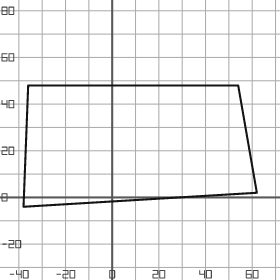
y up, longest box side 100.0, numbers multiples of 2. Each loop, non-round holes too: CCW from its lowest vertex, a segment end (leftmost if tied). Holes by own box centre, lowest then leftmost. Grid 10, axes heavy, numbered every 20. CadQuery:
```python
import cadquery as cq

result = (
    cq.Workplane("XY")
    .moveTo(-38.0, -4.0)
    .lineTo(62.0, 2.0)
    .lineTo(54.0, 48.0)
    .lineTo(-36.0, 48.0)
    .close()
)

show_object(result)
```